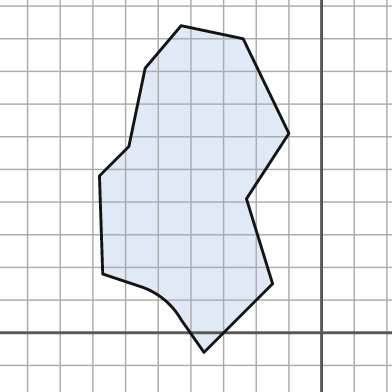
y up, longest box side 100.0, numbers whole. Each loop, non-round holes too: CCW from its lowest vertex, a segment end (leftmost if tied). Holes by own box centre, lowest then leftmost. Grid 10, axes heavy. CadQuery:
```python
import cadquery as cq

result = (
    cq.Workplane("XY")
    .moveTo(-36.0, -6.0)
    .lineTo(-15.0, 15.0)
    .lineTo(-23.0, 41.0)
    .lineTo(-10.0, 61.0)
    .lineTo(-24.0, 90.0)
    .lineTo(-43.0, 94.0)
    .lineTo(-54.0, 81.0)
    .lineTo(-59.0, 57.0)
    .lineTo(-68.0, 48.0)
    .lineTo(-67.0, 18.0)
    .lineTo(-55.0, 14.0)
    .threePointArc((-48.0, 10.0), (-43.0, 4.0))
    .close()
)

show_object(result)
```